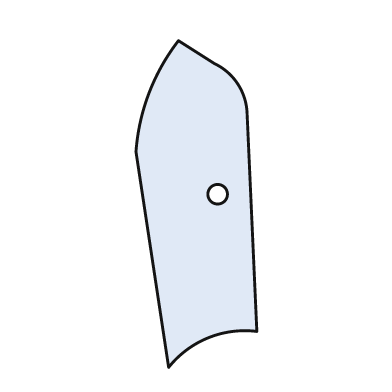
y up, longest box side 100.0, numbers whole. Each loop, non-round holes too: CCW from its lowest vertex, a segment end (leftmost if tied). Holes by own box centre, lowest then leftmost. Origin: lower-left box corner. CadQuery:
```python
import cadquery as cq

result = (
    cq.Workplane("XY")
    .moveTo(10.0, 0.0)
    .threePointArc((22.0, 9.0), (37.0, 11.0))
    .lineTo(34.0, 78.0)
    .threePointArc((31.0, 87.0), (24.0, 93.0))
    .lineTo(13.0, 100.0)
    .threePointArc((4.0, 84.0), (0.0, 66.0))
    .close()
    .moveTo(25.0, 53.0)
    .circle(3.0)
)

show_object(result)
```